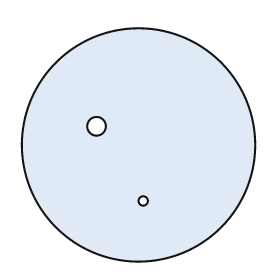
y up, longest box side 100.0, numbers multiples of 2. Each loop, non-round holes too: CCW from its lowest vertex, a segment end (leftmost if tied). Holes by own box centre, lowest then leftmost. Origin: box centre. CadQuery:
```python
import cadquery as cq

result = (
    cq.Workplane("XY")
    .moveTo(0.0, 0.0)
    .circle(50.0)
    .moveTo(2.0, -24.0)
    .circle(2.0)
    .moveTo(-18.0, 8.0)
    .circle(4.0)
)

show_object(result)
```